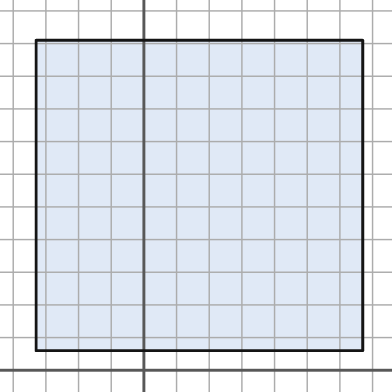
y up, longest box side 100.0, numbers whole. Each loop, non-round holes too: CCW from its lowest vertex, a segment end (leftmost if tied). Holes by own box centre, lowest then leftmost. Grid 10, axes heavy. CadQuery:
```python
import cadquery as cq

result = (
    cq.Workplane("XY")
    .moveTo(-33.0, 6.0)
    .lineTo(67.0, 6.0)
    .lineTo(67.0, 101.0)
    .lineTo(-33.0, 101.0)
    .close()
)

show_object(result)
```